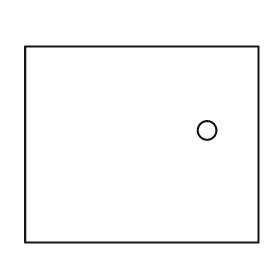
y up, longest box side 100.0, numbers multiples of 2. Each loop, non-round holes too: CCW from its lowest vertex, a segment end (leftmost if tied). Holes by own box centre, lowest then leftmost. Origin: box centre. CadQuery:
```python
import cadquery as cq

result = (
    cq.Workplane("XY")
    .moveTo(-50.0, -42.0)
    .lineTo(50.0, -42.0)
    .lineTo(50.0, 42.0)
    .lineTo(-50.0, 42.0)
    .close()
    .moveTo(28.0, 6.0)
    .circle(4.0)
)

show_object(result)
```